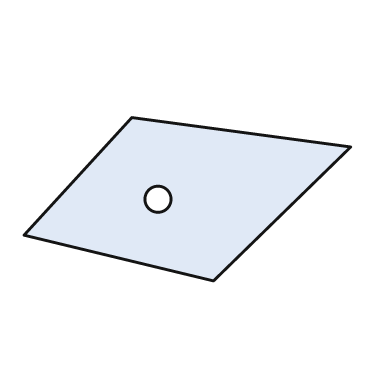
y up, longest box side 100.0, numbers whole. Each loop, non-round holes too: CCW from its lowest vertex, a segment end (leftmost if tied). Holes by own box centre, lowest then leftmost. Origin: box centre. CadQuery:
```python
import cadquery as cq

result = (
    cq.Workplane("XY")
    .moveTo(8.0, -25.0)
    .lineTo(50.0, 16.0)
    .lineTo(-17.0, 25.0)
    .lineTo(-50.0, -11.0)
    .close()
    .moveTo(-9.0, 0.0)
    .circle(4.0)
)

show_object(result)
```